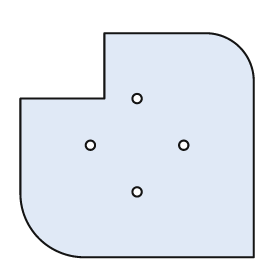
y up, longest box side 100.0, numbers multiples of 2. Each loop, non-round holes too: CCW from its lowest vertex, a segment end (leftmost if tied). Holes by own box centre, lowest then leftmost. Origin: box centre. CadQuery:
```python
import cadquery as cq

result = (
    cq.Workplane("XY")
    .moveTo(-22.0, -48.0)
    .lineTo(50.0, -48.0)
    .lineTo(50.0, 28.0)
    .threePointArc((44.0, 42.0), (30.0, 48.0))
    .lineTo(-14.0, 48.0)
    .lineTo(-14.0, 20.0)
    .lineTo(-50.0, 20.0)
    .lineTo(-50.0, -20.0)
    .threePointArc((-42.0, -40.0), (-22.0, -48.0))
    .close()
    .moveTo(0.0, -20.0)
    .circle(2.0)
    .moveTo(-20.0, 0.0)
    .circle(2.0)
    .moveTo(20.0, 0.0)
    .circle(2.0)
    .moveTo(0.0, 20.0)
    .circle(2.0)
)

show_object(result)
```